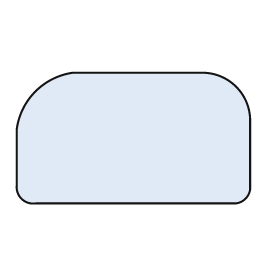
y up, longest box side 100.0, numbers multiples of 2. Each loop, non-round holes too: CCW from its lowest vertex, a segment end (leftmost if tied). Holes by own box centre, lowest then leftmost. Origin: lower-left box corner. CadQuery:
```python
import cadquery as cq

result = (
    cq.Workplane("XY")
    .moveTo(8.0, 0.0)
    .lineTo(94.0, 0.0)
    .threePointArc((98.0, 2.0), (100.0, 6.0))
    .lineTo(100.0, 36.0)
    .threePointArc((94.0, 50.0), (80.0, 56.0))
    .lineTo(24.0, 56.0)
    .threePointArc((8.0, 48.0), (0.0, 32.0))
    .lineTo(0.0, 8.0)
    .threePointArc((2.0, 2.0), (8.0, 0.0))
    .close()
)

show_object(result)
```